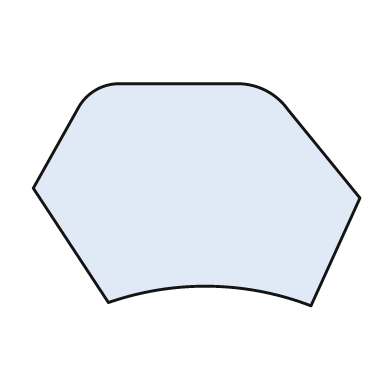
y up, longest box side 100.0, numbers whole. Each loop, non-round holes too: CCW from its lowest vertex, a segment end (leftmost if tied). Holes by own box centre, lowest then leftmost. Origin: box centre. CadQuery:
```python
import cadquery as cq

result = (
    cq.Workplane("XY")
    .moveTo(35.0, -34.0)
    .lineTo(50.0, -1.0)
    .lineTo(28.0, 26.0)
    .threePointArc((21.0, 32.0), (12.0, 34.0))
    .lineTo(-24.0, 34.0)
    .threePointArc((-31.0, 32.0), (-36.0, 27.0))
    .lineTo(-50.0, 2.0)
    .lineTo(-27.0, -33.0)
    .threePointArc((4.0, -28.0), (35.0, -34.0))
    .close()
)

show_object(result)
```